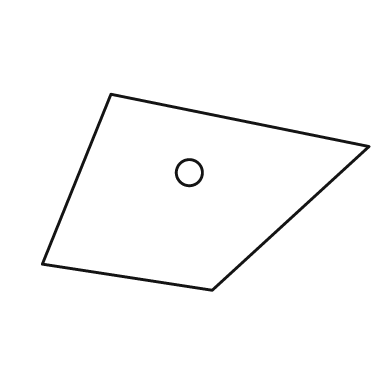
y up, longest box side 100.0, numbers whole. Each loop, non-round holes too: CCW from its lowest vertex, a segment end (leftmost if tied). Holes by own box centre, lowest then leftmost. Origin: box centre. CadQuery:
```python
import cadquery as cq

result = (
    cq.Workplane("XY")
    .moveTo(2.0, -30.0)
    .lineTo(50.0, 14.0)
    .lineTo(-29.0, 30.0)
    .lineTo(-50.0, -22.0)
    .close()
    .moveTo(-5.0, 6.0)
    .circle(4.0)
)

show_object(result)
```